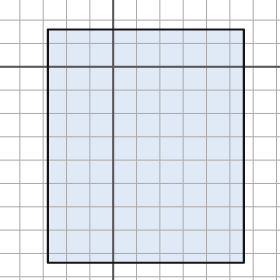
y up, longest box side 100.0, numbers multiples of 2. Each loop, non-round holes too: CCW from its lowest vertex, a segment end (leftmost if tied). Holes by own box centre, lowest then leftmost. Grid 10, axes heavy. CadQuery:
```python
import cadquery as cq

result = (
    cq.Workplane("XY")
    .moveTo(-28.0, -84.0)
    .lineTo(56.0, -84.0)
    .lineTo(56.0, 16.0)
    .lineTo(-28.0, 16.0)
    .close()
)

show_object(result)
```